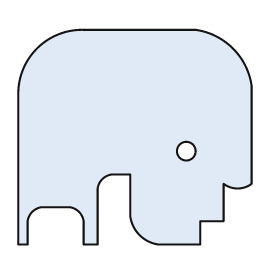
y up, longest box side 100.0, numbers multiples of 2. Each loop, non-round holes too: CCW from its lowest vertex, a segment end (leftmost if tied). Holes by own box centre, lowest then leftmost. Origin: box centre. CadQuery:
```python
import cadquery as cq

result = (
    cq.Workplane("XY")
    .moveTo(-50.0, -46.0)
    .lineTo(-46.0, -46.0)
    .lineTo(-46.0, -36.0)
    .threePointArc((-44.0, -32.0), (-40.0, -30.0))
    .lineTo(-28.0, -30.0)
    .threePointArc((-24.0, -32.0), (-22.0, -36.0))
    .lineTo(-22.0, -46.0)
    .lineTo(-16.0, -46.0)
    .lineTo(-16.0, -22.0)
    .threePointArc((-14.0, -18.0), (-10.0, -16.0))
    .lineTo(-2.0, -16.0)
    .lineTo(-2.0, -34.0)
    .threePointArc((2.0, -42.0), (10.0, -46.0))
    .lineTo(28.0, -46.0)
    .lineTo(28.0, -36.0)
    .lineTo(38.0, -36.0)
    .lineTo(38.0, -20.0)
    .threePointArc((44.0, -22.0), (50.0, -20.0))
    .lineTo(50.0, 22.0)
    .threePointArc((42.0, 38.0), (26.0, 46.0))
    .lineTo(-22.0, 46.0)
    .threePointArc((-42.0, 38.0), (-50.0, 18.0))
    .close()
    .moveTo(22.0, -6.0)
    .circle(4.0)
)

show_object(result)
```